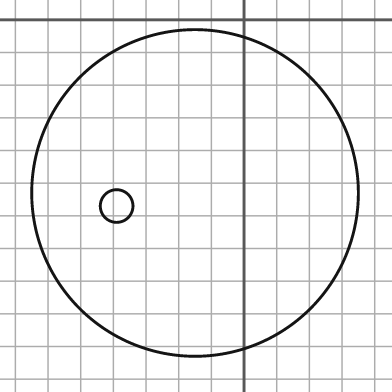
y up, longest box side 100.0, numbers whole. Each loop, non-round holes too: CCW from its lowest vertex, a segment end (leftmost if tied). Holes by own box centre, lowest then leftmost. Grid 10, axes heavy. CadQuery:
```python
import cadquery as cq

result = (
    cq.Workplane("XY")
    .moveTo(-15.0, -53.0)
    .circle(50.0)
    .moveTo(-39.0, -57.0)
    .circle(5.0)
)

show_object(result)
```